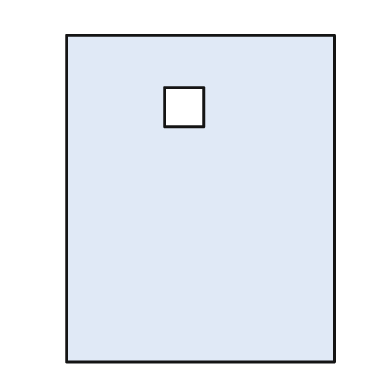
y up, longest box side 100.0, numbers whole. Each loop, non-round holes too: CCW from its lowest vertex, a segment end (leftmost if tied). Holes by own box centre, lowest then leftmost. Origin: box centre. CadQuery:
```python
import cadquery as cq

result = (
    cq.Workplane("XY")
    .moveTo(-41.0, -50.0)
    .lineTo(41.0, -50.0)
    .lineTo(41.0, 50.0)
    .lineTo(-41.0, 50.0)
    .close()
    .moveTo(-11.0, 22.0)
    .lineTo(1.0, 22.0)
    .lineTo(1.0, 34.0)
    .lineTo(-11.0, 34.0)
    .close()
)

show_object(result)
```